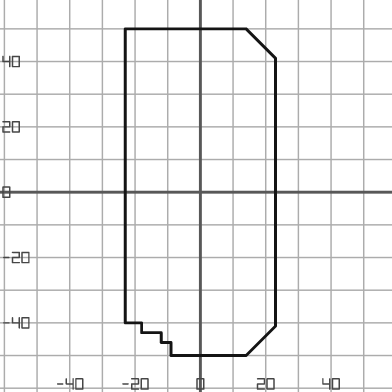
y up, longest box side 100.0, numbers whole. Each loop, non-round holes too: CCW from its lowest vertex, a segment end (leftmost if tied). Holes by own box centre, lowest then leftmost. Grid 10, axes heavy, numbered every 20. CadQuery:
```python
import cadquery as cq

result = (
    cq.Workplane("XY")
    .moveTo(-9.0, -50.0)
    .lineTo(14.0, -50.0)
    .lineTo(23.0, -41.0)
    .lineTo(23.0, 41.0)
    .lineTo(14.0, 50.0)
    .lineTo(-23.0, 50.0)
    .lineTo(-23.0, -40.0)
    .lineTo(-18.0, -40.0)
    .lineTo(-18.0, -43.0)
    .lineTo(-12.0, -43.0)
    .lineTo(-12.0, -46.0)
    .lineTo(-9.0, -46.0)
    .close()
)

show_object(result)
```